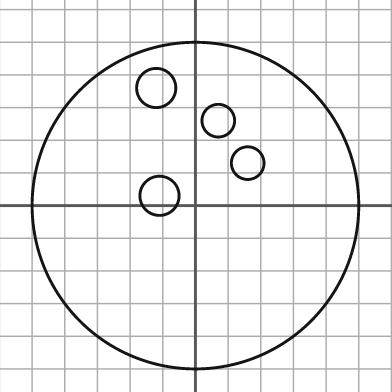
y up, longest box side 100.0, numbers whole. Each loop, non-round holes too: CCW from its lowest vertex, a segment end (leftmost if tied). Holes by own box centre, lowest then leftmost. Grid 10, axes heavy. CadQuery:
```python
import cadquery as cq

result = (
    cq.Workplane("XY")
    .moveTo(0.0, 0.0)
    .circle(50.0)
    .moveTo(-11.0, 3.0)
    .circle(6.0)
    .moveTo(16.0, 13.0)
    .circle(5.0)
    .moveTo(7.0, 26.0)
    .circle(5.0)
    .moveTo(-12.0, 36.0)
    .circle(6.0)
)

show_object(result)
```